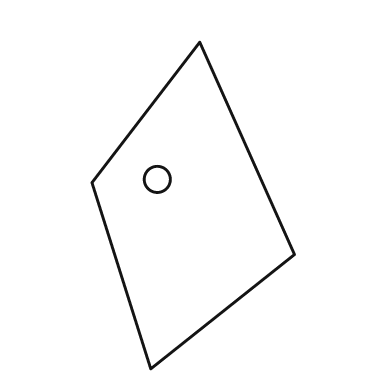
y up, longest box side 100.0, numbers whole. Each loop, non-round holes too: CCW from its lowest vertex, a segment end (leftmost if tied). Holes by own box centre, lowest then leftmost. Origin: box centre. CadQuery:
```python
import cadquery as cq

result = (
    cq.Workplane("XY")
    .moveTo(-13.0, -50.0)
    .lineTo(31.0, -15.0)
    .lineTo(2.0, 50.0)
    .lineTo(-31.0, 7.0)
    .close()
    .moveTo(-11.0, 8.0)
    .circle(4.0)
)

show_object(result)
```